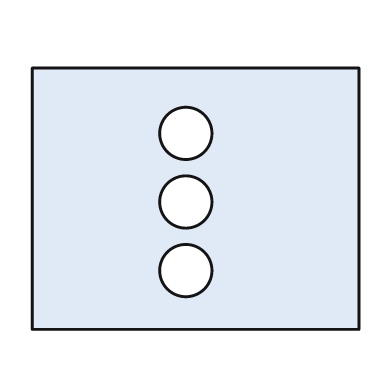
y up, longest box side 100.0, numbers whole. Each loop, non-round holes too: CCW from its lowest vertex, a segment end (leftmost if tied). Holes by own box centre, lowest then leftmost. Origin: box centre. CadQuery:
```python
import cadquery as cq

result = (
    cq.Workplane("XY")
    .moveTo(-50.0, -40.0)
    .lineTo(50.0, -40.0)
    .lineTo(50.0, 40.0)
    .lineTo(-50.0, 40.0)
    .close()
    .moveTo(-3.0, -22.0)
    .circle(8.0)
    .moveTo(-3.0, -1.0)
    .circle(8.0)
    .moveTo(-3.0, 20.0)
    .circle(8.0)
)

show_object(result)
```